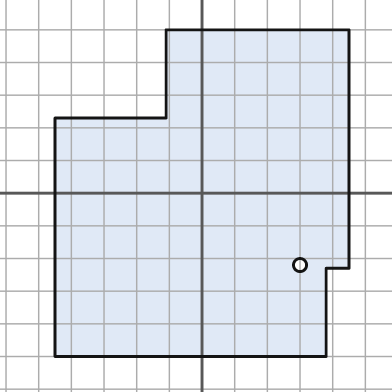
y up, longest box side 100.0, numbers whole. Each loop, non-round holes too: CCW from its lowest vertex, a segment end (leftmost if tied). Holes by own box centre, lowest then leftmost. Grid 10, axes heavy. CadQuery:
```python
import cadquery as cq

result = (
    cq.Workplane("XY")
    .moveTo(-45.0, -50.0)
    .lineTo(38.0, -50.0)
    .lineTo(38.0, -23.0)
    .lineTo(45.0, -23.0)
    .lineTo(45.0, 50.0)
    .lineTo(-11.0, 50.0)
    .lineTo(-11.0, 23.0)
    .lineTo(-45.0, 23.0)
    .close()
    .moveTo(30.0, -22.0)
    .circle(2.0)
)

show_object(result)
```